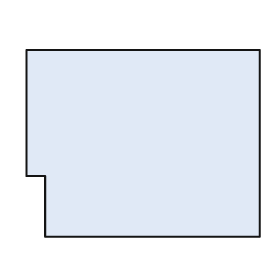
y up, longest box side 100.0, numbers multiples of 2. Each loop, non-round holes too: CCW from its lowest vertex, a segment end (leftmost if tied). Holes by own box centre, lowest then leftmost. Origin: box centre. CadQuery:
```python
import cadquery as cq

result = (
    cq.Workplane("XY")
    .moveTo(-42.0, -40.0)
    .lineTo(50.0, -40.0)
    .lineTo(50.0, 40.0)
    .lineTo(-50.0, 40.0)
    .lineTo(-50.0, -14.0)
    .lineTo(-42.0, -14.0)
    .close()
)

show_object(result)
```